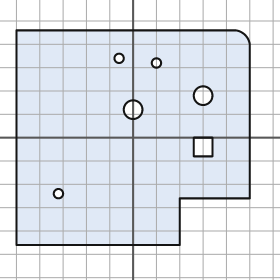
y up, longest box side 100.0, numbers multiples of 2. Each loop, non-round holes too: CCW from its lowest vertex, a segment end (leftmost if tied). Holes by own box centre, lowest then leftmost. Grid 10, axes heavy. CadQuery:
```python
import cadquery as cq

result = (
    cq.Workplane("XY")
    .moveTo(-50.0, -46.0)
    .lineTo(20.0, -46.0)
    .lineTo(20.0, -26.0)
    .lineTo(50.0, -26.0)
    .lineTo(50.0, 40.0)
    .threePointArc((48.0, 44.0), (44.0, 46.0))
    .lineTo(-50.0, 46.0)
    .close()
    .moveTo(-32.0, -24.0)
    .circle(2.0)
    .moveTo(26.0, -8.0)
    .lineTo(34.0, -8.0)
    .lineTo(34.0, 0.0)
    .lineTo(26.0, 0.0)
    .close()
    .moveTo(0.0, 12.0)
    .circle(4.0)
    .moveTo(30.0, 18.0)
    .circle(4.0)
    .moveTo(10.0, 32.0)
    .circle(2.0)
    .moveTo(-6.0, 34.0)
    .circle(2.0)
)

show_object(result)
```